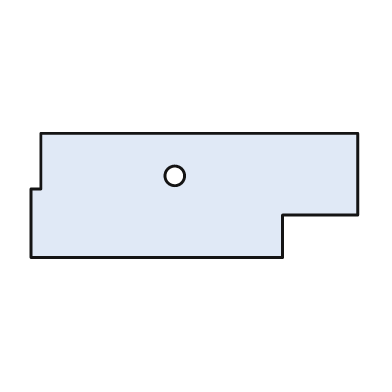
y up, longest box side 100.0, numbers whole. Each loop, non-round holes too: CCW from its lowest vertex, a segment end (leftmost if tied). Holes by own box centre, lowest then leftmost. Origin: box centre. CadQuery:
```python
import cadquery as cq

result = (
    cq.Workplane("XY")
    .moveTo(-50.0, -19.0)
    .lineTo(27.0, -19.0)
    .lineTo(27.0, -6.0)
    .lineTo(50.0, -6.0)
    .lineTo(50.0, 19.0)
    .lineTo(-47.0, 19.0)
    .lineTo(-47.0, 2.0)
    .lineTo(-50.0, 2.0)
    .close()
    .moveTo(-6.0, 6.0)
    .circle(3.0)
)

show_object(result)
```